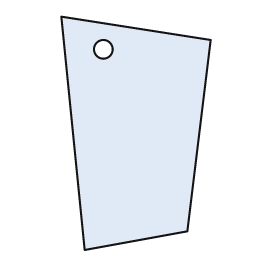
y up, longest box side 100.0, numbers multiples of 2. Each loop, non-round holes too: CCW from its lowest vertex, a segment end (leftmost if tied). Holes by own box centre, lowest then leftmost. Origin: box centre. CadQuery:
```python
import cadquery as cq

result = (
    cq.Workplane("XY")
    .moveTo(-22.0, -50.0)
    .lineTo(22.0, -42.0)
    .lineTo(32.0, 40.0)
    .lineTo(-32.0, 50.0)
    .close()
    .moveTo(-14.0, 36.0)
    .circle(4.0)
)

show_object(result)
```